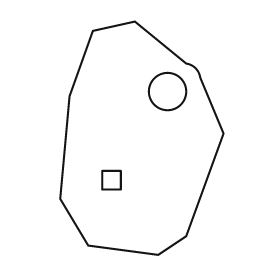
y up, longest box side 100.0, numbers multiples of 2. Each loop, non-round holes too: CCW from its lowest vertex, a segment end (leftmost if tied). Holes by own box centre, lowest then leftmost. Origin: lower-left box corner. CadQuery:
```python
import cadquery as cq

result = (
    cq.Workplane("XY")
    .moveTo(42.0, 0.0)
    .lineTo(54.0, 8.0)
    .lineTo(70.0, 52.0)
    .lineTo(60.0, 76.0)
    .threePointArc((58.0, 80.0), (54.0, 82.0))
    .lineTo(32.0, 100.0)
    .lineTo(14.0, 96.0)
    .lineTo(4.0, 68.0)
    .lineTo(0.0, 24.0)
    .lineTo(12.0, 4.0)
    .close()
    .moveTo(18.0, 28.0)
    .lineTo(26.0, 28.0)
    .lineTo(26.0, 36.0)
    .lineTo(18.0, 36.0)
    .close()
    .moveTo(46.0, 70.0)
    .circle(8.0)
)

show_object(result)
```